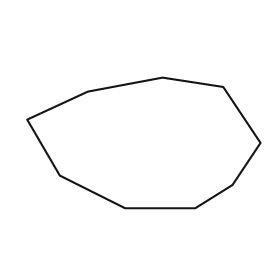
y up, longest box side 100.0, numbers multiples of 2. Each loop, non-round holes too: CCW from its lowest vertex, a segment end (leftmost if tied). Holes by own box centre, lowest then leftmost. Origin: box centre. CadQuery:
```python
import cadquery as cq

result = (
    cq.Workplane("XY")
    .moveTo(-8.0, -28.0)
    .lineTo(22.0, -28.0)
    .lineTo(38.0, -18.0)
    .lineTo(50.0, 0.0)
    .lineTo(34.0, 24.0)
    .lineTo(8.0, 28.0)
    .lineTo(-24.0, 22.0)
    .lineTo(-50.0, 10.0)
    .lineTo(-36.0, -14.0)
    .close()
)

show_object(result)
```